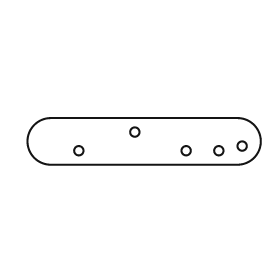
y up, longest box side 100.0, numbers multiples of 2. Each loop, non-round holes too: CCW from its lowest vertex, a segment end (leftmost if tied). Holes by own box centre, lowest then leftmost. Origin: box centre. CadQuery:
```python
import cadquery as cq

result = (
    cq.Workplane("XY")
    .moveTo(-40.0, -10.0)
    .lineTo(40.0, -10.0)
    .threePointArc((50.0, 0.0), (40.0, 10.0))
    .lineTo(-40.0, 10.0)
    .threePointArc((-50.0, 0.0), (-40.0, -10.0))
    .close()
    .moveTo(-28.0, -4.0)
    .circle(2.0)
    .moveTo(18.0, -4.0)
    .circle(2.0)
    .moveTo(32.0, -4.0)
    .circle(2.0)
    .moveTo(42.0, -2.0)
    .circle(2.0)
    .moveTo(-4.0, 4.0)
    .circle(2.0)
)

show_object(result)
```